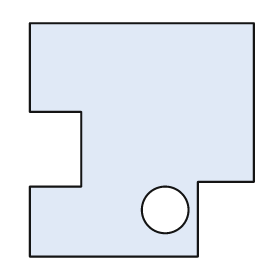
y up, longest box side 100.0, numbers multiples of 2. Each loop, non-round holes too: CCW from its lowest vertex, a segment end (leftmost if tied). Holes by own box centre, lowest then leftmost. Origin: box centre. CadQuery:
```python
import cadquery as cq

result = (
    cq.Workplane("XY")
    .moveTo(-48.0, -50.0)
    .lineTo(24.0, -50.0)
    .lineTo(24.0, -18.0)
    .lineTo(48.0, -18.0)
    .lineTo(48.0, 50.0)
    .lineTo(-48.0, 50.0)
    .lineTo(-48.0, 12.0)
    .lineTo(-26.0, 12.0)
    .lineTo(-26.0, -20.0)
    .lineTo(-48.0, -20.0)
    .close()
    .moveTo(10.0, -30.0)
    .circle(10.0)
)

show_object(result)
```